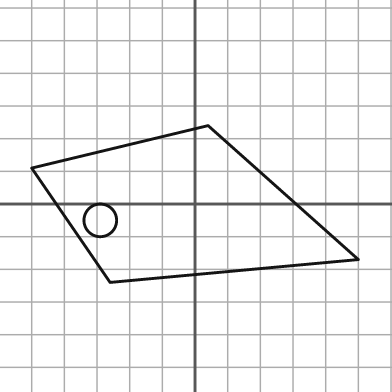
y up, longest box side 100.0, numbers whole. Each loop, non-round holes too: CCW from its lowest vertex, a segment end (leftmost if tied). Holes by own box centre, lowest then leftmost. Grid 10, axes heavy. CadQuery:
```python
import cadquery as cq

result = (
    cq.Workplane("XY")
    .moveTo(-26.0, -24.0)
    .lineTo(50.0, -17.0)
    .lineTo(4.0, 24.0)
    .lineTo(-50.0, 11.0)
    .close()
    .moveTo(-29.0, -5.0)
    .circle(5.0)
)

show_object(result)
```